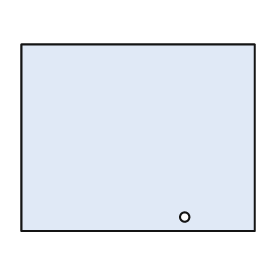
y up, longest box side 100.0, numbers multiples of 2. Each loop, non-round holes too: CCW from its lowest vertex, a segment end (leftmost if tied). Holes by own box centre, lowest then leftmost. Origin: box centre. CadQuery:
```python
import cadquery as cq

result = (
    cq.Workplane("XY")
    .moveTo(-50.0, -40.0)
    .lineTo(50.0, -40.0)
    .lineTo(50.0, 40.0)
    .lineTo(-50.0, 40.0)
    .close()
    .moveTo(20.0, -34.0)
    .circle(2.0)
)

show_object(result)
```